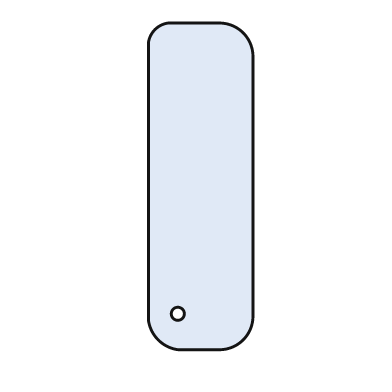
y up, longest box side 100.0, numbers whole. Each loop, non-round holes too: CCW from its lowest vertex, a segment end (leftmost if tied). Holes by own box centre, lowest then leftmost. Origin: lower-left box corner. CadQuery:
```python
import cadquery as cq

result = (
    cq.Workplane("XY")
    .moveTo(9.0, 0.0)
    .lineTo(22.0, 0.0)
    .threePointArc((29.0, 3.0), (32.0, 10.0))
    .lineTo(32.0, 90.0)
    .threePointArc((29.0, 97.0), (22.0, 100.0))
    .lineTo(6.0, 100.0)
    .threePointArc((2.0, 98.0), (0.0, 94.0))
    .lineTo(0.0, 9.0)
    .threePointArc((3.0, 3.0), (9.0, 0.0))
    .close()
    .moveTo(9.0, 11.0)
    .circle(2.0)
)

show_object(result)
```